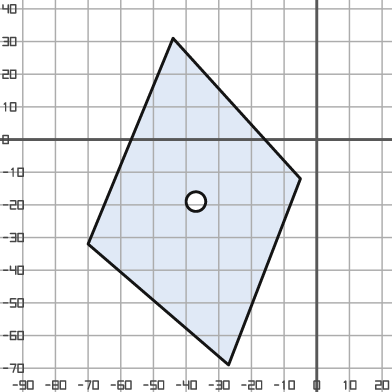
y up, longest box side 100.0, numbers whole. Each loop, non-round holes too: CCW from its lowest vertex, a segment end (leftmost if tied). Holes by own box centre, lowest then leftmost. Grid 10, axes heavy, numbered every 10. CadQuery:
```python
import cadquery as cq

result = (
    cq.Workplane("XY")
    .moveTo(-27.0, -69.0)
    .lineTo(-5.0, -12.0)
    .lineTo(-44.0, 31.0)
    .lineTo(-70.0, -32.0)
    .close()
    .moveTo(-37.0, -19.0)
    .circle(3.0)
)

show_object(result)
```